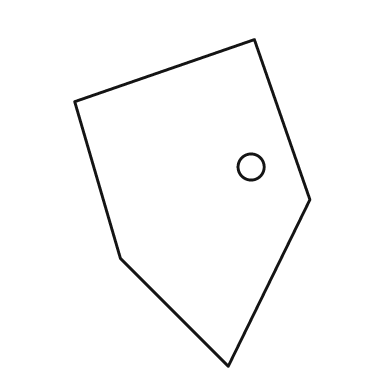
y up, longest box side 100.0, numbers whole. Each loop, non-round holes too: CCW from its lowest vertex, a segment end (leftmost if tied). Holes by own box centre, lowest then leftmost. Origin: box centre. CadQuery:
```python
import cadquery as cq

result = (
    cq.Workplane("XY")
    .moveTo(11.0, -50.0)
    .lineTo(36.0, 1.0)
    .lineTo(19.0, 50.0)
    .lineTo(-36.0, 31.0)
    .lineTo(-22.0, -17.0)
    .close()
    .moveTo(18.0, 11.0)
    .circle(4.0)
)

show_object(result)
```